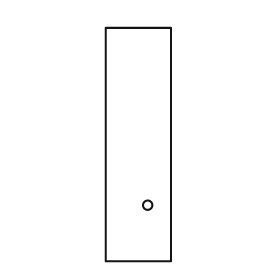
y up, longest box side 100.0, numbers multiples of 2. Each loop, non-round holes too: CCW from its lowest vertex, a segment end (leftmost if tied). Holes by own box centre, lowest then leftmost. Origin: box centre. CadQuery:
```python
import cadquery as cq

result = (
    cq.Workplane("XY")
    .moveTo(-14.0, -50.0)
    .lineTo(14.0, -50.0)
    .lineTo(14.0, 50.0)
    .lineTo(-14.0, 50.0)
    .close()
    .moveTo(4.0, -26.0)
    .circle(2.0)
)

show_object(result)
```